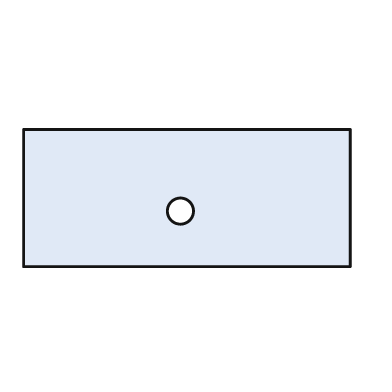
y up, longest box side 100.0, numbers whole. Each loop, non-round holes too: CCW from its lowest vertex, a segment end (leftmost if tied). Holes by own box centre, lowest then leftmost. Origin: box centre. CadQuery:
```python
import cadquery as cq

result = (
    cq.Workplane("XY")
    .moveTo(-50.0, -21.0)
    .lineTo(50.0, -21.0)
    .lineTo(50.0, 21.0)
    .lineTo(-50.0, 21.0)
    .close()
    .moveTo(-2.0, -4.0)
    .circle(4.0)
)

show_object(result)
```